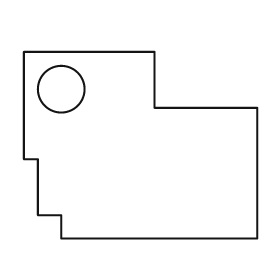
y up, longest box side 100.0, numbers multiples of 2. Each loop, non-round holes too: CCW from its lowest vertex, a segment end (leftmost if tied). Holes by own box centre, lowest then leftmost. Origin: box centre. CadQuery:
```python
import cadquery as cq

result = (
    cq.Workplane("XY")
    .moveTo(-34.0, -40.0)
    .lineTo(50.0, -40.0)
    .lineTo(50.0, 16.0)
    .lineTo(6.0, 16.0)
    .lineTo(6.0, 40.0)
    .lineTo(-50.0, 40.0)
    .lineTo(-50.0, -6.0)
    .lineTo(-44.0, -6.0)
    .lineTo(-44.0, -30.0)
    .lineTo(-34.0, -30.0)
    .close()
    .moveTo(-34.0, 24.0)
    .circle(10.0)
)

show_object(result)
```